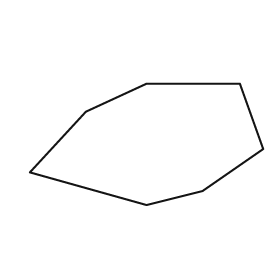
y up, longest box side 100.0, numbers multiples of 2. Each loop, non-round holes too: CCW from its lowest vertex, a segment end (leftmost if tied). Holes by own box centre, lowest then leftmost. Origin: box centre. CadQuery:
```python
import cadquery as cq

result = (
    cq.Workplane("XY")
    .moveTo(0.0, -26.0)
    .lineTo(24.0, -20.0)
    .lineTo(50.0, -2.0)
    .lineTo(40.0, 26.0)
    .lineTo(0.0, 26.0)
    .lineTo(-26.0, 14.0)
    .lineTo(-50.0, -12.0)
    .close()
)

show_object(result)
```